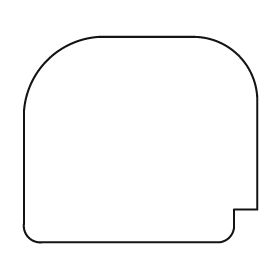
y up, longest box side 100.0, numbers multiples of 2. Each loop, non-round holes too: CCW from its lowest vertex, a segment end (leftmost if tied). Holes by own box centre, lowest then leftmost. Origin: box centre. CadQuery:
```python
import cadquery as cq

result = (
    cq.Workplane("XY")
    .moveTo(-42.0, -44.0)
    .lineTo(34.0, -44.0)
    .threePointArc((38.0, -42.0), (40.0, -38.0))
    .lineTo(40.0, -30.0)
    .lineTo(50.0, -30.0)
    .lineTo(50.0, 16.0)
    .threePointArc((42.0, 36.0), (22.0, 44.0))
    .lineTo(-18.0, 44.0)
    .threePointArc((-40.0, 34.0), (-50.0, 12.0))
    .lineTo(-50.0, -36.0)
    .threePointArc((-48.0, -42.0), (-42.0, -44.0))
    .close()
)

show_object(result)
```